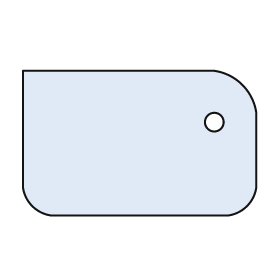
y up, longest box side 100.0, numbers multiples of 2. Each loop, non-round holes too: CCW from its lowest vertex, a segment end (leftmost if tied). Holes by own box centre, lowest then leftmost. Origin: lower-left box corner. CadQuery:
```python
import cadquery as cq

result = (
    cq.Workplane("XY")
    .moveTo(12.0, 0.0)
    .lineTo(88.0, 0.0)
    .threePointArc((96.0, 4.0), (100.0, 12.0))
    .lineTo(100.0, 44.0)
    .threePointArc((94.0, 56.0), (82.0, 62.0))
    .lineTo(0.0, 62.0)
    .lineTo(0.0, 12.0)
    .threePointArc((4.0, 4.0), (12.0, 0.0))
    .close()
    .moveTo(82.0, 40.0)
    .circle(4.0)
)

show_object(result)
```